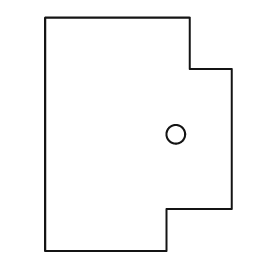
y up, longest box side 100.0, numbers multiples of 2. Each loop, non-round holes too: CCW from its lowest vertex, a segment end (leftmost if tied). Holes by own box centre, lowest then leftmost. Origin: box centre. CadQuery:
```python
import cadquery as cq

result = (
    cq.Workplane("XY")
    .moveTo(-40.0, -50.0)
    .lineTo(12.0, -50.0)
    .lineTo(12.0, -32.0)
    .lineTo(40.0, -32.0)
    .lineTo(40.0, 28.0)
    .lineTo(22.0, 28.0)
    .lineTo(22.0, 50.0)
    .lineTo(-40.0, 50.0)
    .close()
    .moveTo(16.0, 0.0)
    .circle(4.0)
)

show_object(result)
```